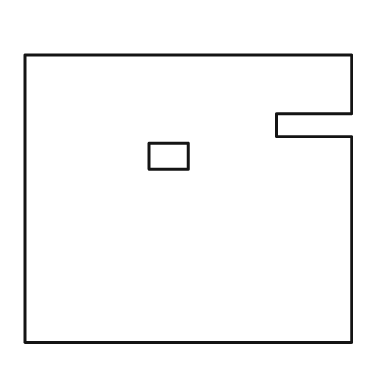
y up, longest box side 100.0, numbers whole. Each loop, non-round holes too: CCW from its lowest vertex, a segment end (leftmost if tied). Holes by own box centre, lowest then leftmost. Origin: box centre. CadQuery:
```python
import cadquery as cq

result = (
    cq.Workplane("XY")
    .moveTo(-50.0, -44.0)
    .lineTo(50.0, -44.0)
    .lineTo(50.0, 19.0)
    .lineTo(27.0, 19.0)
    .lineTo(27.0, 26.0)
    .lineTo(50.0, 26.0)
    .lineTo(50.0, 44.0)
    .lineTo(-50.0, 44.0)
    .close()
    .moveTo(-12.0, 9.0)
    .lineTo(0.0, 9.0)
    .lineTo(0.0, 17.0)
    .lineTo(-12.0, 17.0)
    .close()
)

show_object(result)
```